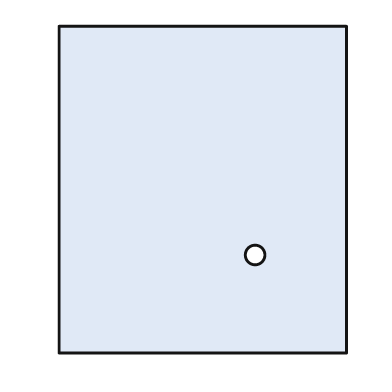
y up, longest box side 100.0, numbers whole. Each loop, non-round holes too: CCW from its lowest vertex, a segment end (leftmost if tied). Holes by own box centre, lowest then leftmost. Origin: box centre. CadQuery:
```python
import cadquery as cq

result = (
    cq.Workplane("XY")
    .moveTo(-44.0, -50.0)
    .lineTo(44.0, -50.0)
    .lineTo(44.0, 50.0)
    .lineTo(-44.0, 50.0)
    .close()
    .moveTo(16.0, -20.0)
    .circle(3.0)
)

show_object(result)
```